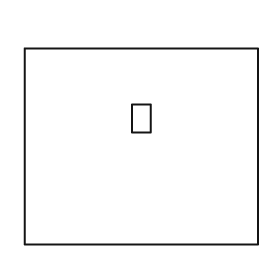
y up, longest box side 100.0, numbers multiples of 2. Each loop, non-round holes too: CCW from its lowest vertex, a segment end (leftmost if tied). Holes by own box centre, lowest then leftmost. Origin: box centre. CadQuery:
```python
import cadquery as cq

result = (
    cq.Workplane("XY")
    .moveTo(-50.0, -42.0)
    .lineTo(50.0, -42.0)
    .lineTo(50.0, 42.0)
    .lineTo(-50.0, 42.0)
    .close()
    .moveTo(-4.0, 6.0)
    .lineTo(4.0, 6.0)
    .lineTo(4.0, 18.0)
    .lineTo(-4.0, 18.0)
    .close()
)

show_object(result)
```